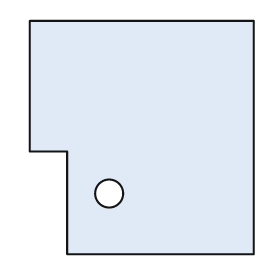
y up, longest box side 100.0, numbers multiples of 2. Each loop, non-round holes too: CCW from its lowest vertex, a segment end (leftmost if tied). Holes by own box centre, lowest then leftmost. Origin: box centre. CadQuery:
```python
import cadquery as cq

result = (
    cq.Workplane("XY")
    .moveTo(-32.0, -50.0)
    .lineTo(48.0, -50.0)
    .lineTo(48.0, 50.0)
    .lineTo(-48.0, 50.0)
    .lineTo(-48.0, -6.0)
    .lineTo(-32.0, -6.0)
    .close()
    .moveTo(-14.0, -24.0)
    .circle(6.0)
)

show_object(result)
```